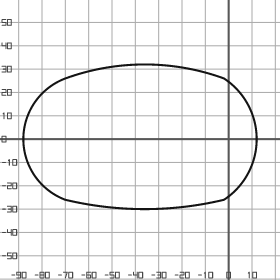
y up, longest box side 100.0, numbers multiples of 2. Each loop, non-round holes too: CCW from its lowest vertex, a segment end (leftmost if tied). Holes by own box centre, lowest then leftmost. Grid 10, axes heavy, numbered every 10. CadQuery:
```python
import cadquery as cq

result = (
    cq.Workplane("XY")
    .moveTo(-70.0, -26.0)
    .threePointArc((-36.0, -30.0), (-2.0, -26.0))
    .threePointArc((12.0, 0.0), (-2.0, 26.0))
    .threePointArc((-36.0, 32.0), (-70.0, 26.0))
    .threePointArc((-88.0, 0.0), (-70.0, -26.0))
    .close()
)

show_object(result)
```